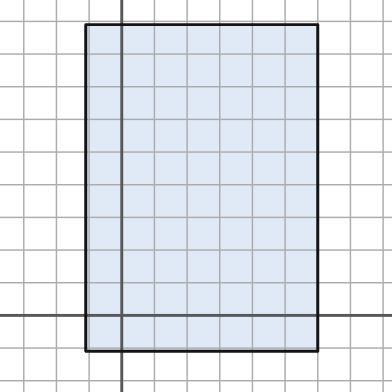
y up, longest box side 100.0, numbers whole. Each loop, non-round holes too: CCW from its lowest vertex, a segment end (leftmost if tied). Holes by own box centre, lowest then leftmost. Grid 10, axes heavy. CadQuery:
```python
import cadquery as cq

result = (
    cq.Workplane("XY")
    .moveTo(-11.0, -11.0)
    .lineTo(60.0, -11.0)
    .lineTo(60.0, 89.0)
    .lineTo(-11.0, 89.0)
    .close()
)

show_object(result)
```